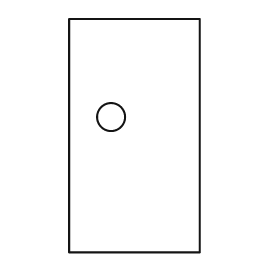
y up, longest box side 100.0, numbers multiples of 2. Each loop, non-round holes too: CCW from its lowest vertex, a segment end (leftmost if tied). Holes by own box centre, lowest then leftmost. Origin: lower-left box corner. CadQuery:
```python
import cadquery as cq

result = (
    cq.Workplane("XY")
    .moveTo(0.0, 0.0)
    .lineTo(56.0, 0.0)
    .lineTo(56.0, 100.0)
    .lineTo(0.0, 100.0)
    .close()
    .moveTo(18.0, 58.0)
    .circle(6.0)
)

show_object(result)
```